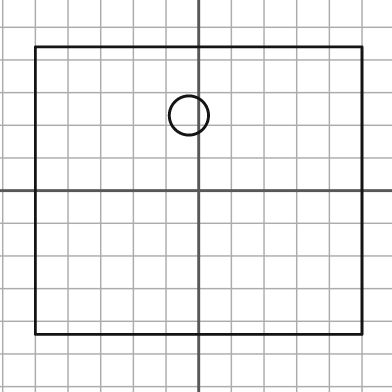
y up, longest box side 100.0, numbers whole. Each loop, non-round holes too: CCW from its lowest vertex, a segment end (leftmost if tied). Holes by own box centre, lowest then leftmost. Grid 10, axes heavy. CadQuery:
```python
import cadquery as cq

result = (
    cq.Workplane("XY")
    .moveTo(-50.0, -44.0)
    .lineTo(50.0, -44.0)
    .lineTo(50.0, 44.0)
    .lineTo(-50.0, 44.0)
    .close()
    .moveTo(-3.0, 23.0)
    .circle(6.0)
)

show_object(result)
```